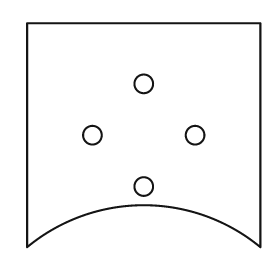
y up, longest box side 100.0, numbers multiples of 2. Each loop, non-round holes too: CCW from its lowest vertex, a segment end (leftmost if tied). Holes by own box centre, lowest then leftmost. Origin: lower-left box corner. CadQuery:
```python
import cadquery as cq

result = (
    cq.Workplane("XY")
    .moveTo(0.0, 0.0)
    .threePointArc((50.0, 18.0), (100.0, 0.0))
    .lineTo(100.0, 96.0)
    .lineTo(0.0, 96.0)
    .close()
    .moveTo(50.0, 26.0)
    .circle(4.0)
    .moveTo(28.0, 48.0)
    .circle(4.0)
    .moveTo(72.0, 48.0)
    .circle(4.0)
    .moveTo(50.0, 70.0)
    .circle(4.0)
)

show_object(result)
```